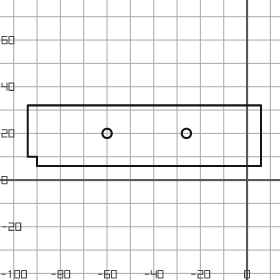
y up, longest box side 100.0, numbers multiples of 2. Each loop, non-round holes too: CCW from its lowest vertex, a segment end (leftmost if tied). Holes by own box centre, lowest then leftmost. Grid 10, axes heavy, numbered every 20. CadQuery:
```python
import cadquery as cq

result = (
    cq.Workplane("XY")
    .moveTo(-90.0, 6.0)
    .lineTo(6.0, 6.0)
    .lineTo(6.0, 32.0)
    .lineTo(-94.0, 32.0)
    .lineTo(-94.0, 10.0)
    .lineTo(-90.0, 10.0)
    .close()
    .moveTo(-60.0, 20.0)
    .circle(2.0)
    .moveTo(-26.0, 20.0)
    .circle(2.0)
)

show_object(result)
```